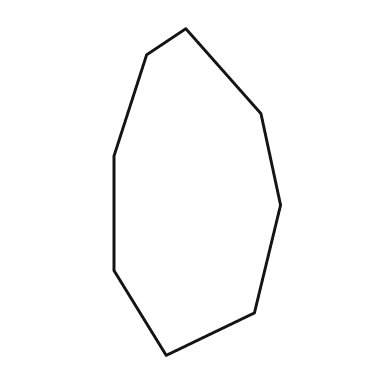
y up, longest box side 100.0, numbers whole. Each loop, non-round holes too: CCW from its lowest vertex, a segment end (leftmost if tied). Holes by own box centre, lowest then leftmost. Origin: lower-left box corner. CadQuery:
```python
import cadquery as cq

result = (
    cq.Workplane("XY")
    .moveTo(16.0, 0.0)
    .lineTo(43.0, 13.0)
    .lineTo(51.0, 46.0)
    .lineTo(45.0, 74.0)
    .lineTo(22.0, 100.0)
    .lineTo(10.0, 92.0)
    .lineTo(0.0, 61.0)
    .lineTo(0.0, 26.0)
    .close()
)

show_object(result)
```